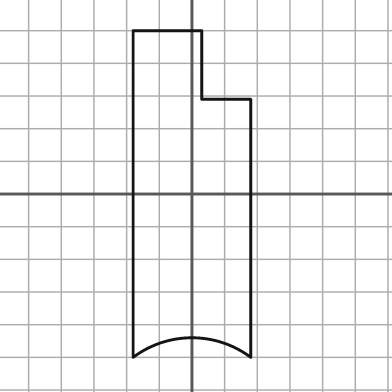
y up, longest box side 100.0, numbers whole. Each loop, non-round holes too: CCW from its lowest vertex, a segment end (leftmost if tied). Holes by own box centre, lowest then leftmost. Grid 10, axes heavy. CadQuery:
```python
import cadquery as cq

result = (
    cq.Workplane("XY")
    .moveTo(-18.0, -50.0)
    .threePointArc((0.0, -44.0), (18.0, -50.0))
    .lineTo(18.0, 29.0)
    .lineTo(3.0, 29.0)
    .lineTo(3.0, 50.0)
    .lineTo(-18.0, 50.0)
    .close()
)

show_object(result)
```